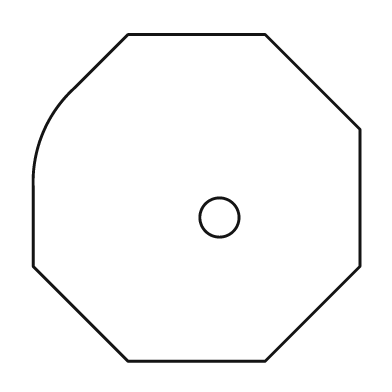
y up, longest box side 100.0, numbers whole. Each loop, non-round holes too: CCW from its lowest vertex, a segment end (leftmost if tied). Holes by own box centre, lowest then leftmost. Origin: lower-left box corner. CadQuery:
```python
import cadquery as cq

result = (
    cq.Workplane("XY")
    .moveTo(29.0, 0.0)
    .lineTo(71.0, 0.0)
    .lineTo(100.0, 29.0)
    .lineTo(100.0, 71.0)
    .lineTo(71.0, 100.0)
    .lineTo(29.0, 100.0)
    .lineTo(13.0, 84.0)
    .threePointArc((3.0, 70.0), (0.0, 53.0))
    .lineTo(0.0, 29.0)
    .close()
    .moveTo(57.0, 44.0)
    .circle(6.0)
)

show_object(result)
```